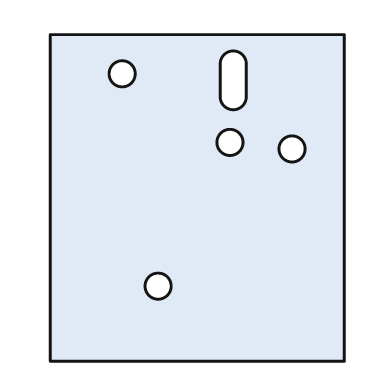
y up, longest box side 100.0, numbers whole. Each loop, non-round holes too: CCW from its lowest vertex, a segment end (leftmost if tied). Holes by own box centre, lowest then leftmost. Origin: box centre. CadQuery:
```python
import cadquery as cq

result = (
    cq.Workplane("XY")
    .moveTo(-45.0, -50.0)
    .lineTo(45.0, -50.0)
    .lineTo(45.0, 50.0)
    .lineTo(-45.0, 50.0)
    .close()
    .moveTo(-12.0, -27.0)
    .circle(4.0)
    .moveTo(29.0, 15.0)
    .circle(4.0)
    .moveTo(10.0, 17.0)
    .circle(4.0)
    .moveTo(7.0, 31.0)
    .threePointArc((11.0, 27.0), (15.0, 31.0))
    .lineTo(15.0, 41.0)
    .threePointArc((11.0, 45.0), (7.0, 41.0))
    .close()
    .moveTo(-23.0, 38.0)
    .circle(4.0)
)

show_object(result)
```